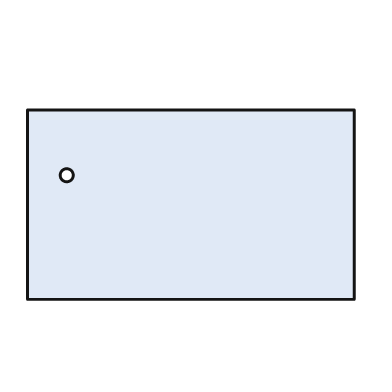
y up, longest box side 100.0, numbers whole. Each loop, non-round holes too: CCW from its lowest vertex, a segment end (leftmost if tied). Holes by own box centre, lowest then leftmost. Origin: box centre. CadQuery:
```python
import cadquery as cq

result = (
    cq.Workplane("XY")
    .moveTo(-50.0, -29.0)
    .lineTo(50.0, -29.0)
    .lineTo(50.0, 29.0)
    .lineTo(-50.0, 29.0)
    .close()
    .moveTo(-38.0, 9.0)
    .circle(2.0)
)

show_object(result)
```